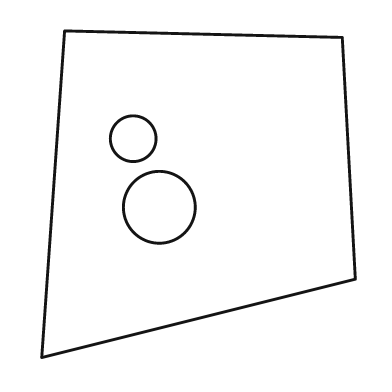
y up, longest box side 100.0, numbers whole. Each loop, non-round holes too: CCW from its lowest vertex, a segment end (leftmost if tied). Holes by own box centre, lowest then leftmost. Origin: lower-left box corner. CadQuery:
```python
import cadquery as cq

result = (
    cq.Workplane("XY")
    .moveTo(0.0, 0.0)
    .lineTo(96.0, 24.0)
    .lineTo(92.0, 98.0)
    .lineTo(7.0, 100.0)
    .close()
    .moveTo(36.0, 46.0)
    .circle(11.0)
    .moveTo(28.0, 67.0)
    .circle(7.0)
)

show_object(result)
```